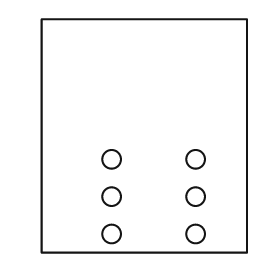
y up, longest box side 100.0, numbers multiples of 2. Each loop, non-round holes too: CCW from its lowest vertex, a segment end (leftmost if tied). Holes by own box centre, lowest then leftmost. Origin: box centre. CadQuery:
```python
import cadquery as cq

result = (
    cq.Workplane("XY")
    .moveTo(-44.0, -50.0)
    .lineTo(44.0, -50.0)
    .lineTo(44.0, 50.0)
    .lineTo(-44.0, 50.0)
    .close()
    .moveTo(-14.0, -42.0)
    .circle(4.0)
    .moveTo(22.0, -42.0)
    .circle(4.0)
    .moveTo(-14.0, -26.0)
    .circle(4.0)
    .moveTo(22.0, -26.0)
    .circle(4.0)
    .moveTo(-14.0, -10.0)
    .circle(4.0)
    .moveTo(22.0, -10.0)
    .circle(4.0)
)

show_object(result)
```